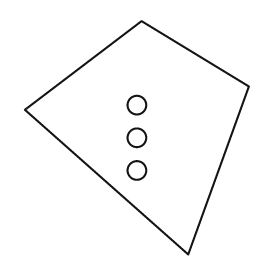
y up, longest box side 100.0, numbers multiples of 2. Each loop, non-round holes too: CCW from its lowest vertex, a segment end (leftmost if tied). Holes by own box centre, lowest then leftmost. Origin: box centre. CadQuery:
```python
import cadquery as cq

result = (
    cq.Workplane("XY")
    .moveTo(22.0, -50.0)
    .lineTo(48.0, 22.0)
    .lineTo(2.0, 50.0)
    .lineTo(-48.0, 12.0)
    .close()
    .moveTo(0.0, -14.0)
    .circle(4.0)
    .moveTo(0.0, 0.0)
    .circle(4.0)
    .moveTo(0.0, 14.0)
    .circle(4.0)
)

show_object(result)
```